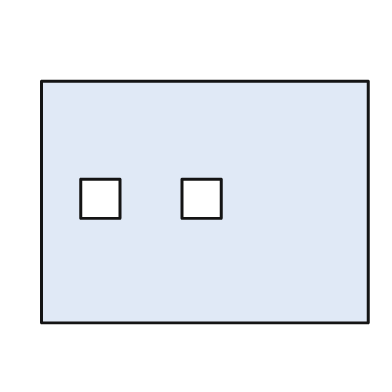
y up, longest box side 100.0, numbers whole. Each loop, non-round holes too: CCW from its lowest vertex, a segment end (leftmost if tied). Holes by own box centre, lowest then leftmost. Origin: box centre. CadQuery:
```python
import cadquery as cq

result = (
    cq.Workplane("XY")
    .moveTo(-50.0, -37.0)
    .lineTo(50.0, -37.0)
    .lineTo(50.0, 37.0)
    .lineTo(-50.0, 37.0)
    .close()
    .moveTo(-38.0, -5.0)
    .lineTo(-26.0, -5.0)
    .lineTo(-26.0, 7.0)
    .lineTo(-38.0, 7.0)
    .close()
    .moveTo(-7.0, -5.0)
    .lineTo(5.0, -5.0)
    .lineTo(5.0, 7.0)
    .lineTo(-7.0, 7.0)
    .close()
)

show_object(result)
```